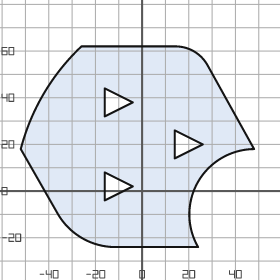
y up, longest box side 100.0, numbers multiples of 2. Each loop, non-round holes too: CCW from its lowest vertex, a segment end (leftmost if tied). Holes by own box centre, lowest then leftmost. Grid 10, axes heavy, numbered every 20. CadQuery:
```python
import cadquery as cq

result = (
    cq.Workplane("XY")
    .moveTo(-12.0, -24.0)
    .lineTo(24.0, -24.0)
    .threePointArc((24.0, 4.0), (48.0, 18.0))
    .lineTo(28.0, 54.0)
    .threePointArc((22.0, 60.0), (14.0, 62.0))
    .lineTo(-26.0, 62.0)
    .threePointArc((-42.0, 42.0), (-52.0, 18.0))
    .lineTo(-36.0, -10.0)
    .threePointArc((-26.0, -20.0), (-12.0, -24.0))
    .close()
    .moveTo(-16.0, -4.0)
    .lineTo(-4.0, 2.0)
    .lineTo(-16.0, 8.0)
    .close()
    .moveTo(14.0, 14.0)
    .lineTo(26.0, 20.0)
    .lineTo(14.0, 26.0)
    .close()
    .moveTo(-16.0, 32.0)
    .lineTo(-4.0, 38.0)
    .lineTo(-16.0, 44.0)
    .close()
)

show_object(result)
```